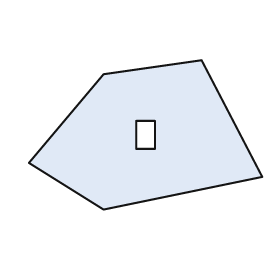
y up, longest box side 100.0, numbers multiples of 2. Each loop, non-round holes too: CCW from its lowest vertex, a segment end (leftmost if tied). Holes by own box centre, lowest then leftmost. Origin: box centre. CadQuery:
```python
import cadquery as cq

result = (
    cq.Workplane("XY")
    .moveTo(-18.0, -32.0)
    .lineTo(50.0, -18.0)
    .lineTo(24.0, 32.0)
    .lineTo(-18.0, 26.0)
    .lineTo(-50.0, -12.0)
    .close()
    .moveTo(-4.0, -6.0)
    .lineTo(4.0, -6.0)
    .lineTo(4.0, 6.0)
    .lineTo(-4.0, 6.0)
    .close()
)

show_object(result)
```